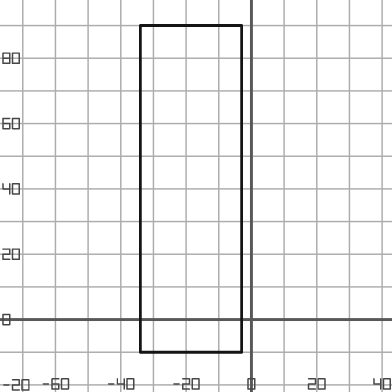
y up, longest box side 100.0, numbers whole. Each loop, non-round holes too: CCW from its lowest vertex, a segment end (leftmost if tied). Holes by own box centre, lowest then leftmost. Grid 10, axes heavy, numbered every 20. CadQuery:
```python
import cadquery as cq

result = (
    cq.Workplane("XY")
    .moveTo(-34.0, -10.0)
    .lineTo(-3.0, -10.0)
    .lineTo(-3.0, 90.0)
    .lineTo(-34.0, 90.0)
    .close()
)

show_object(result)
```